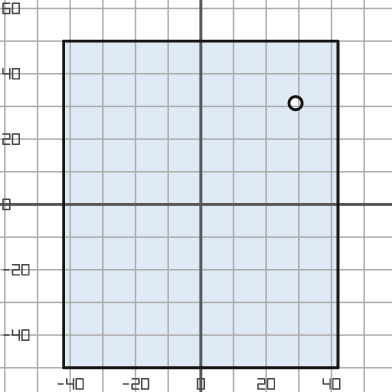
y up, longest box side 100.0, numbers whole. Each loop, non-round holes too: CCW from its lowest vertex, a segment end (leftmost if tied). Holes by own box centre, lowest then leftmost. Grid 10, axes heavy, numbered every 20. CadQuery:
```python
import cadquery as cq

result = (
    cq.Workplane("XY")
    .moveTo(-42.0, -50.0)
    .lineTo(42.0, -50.0)
    .lineTo(42.0, 50.0)
    .lineTo(-42.0, 50.0)
    .close()
    .moveTo(29.0, 31.0)
    .circle(2.0)
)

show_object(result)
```